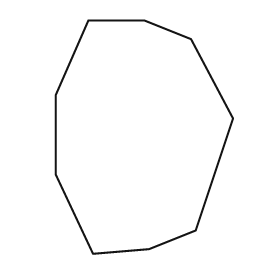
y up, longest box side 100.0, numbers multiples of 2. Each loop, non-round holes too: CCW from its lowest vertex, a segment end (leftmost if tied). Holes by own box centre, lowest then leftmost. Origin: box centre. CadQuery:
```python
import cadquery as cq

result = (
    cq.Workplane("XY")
    .moveTo(-22.0, -50.0)
    .lineTo(2.0, -48.0)
    .lineTo(22.0, -40.0)
    .lineTo(38.0, 8.0)
    .lineTo(20.0, 42.0)
    .lineTo(0.0, 50.0)
    .lineTo(-24.0, 50.0)
    .lineTo(-38.0, 18.0)
    .lineTo(-38.0, -16.0)
    .close()
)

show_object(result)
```